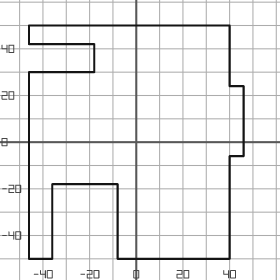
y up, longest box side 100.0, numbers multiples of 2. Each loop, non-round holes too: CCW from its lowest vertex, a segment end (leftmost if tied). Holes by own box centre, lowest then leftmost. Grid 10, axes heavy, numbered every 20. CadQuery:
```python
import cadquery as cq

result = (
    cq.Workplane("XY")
    .moveTo(-46.0, -50.0)
    .lineTo(-36.0, -50.0)
    .lineTo(-36.0, -18.0)
    .lineTo(-8.0, -18.0)
    .lineTo(-8.0, -50.0)
    .lineTo(40.0, -50.0)
    .lineTo(40.0, -6.0)
    .lineTo(46.0, -6.0)
    .lineTo(46.0, 24.0)
    .lineTo(40.0, 24.0)
    .lineTo(40.0, 50.0)
    .lineTo(-46.0, 50.0)
    .lineTo(-46.0, 42.0)
    .lineTo(-18.0, 42.0)
    .lineTo(-18.0, 30.0)
    .lineTo(-46.0, 30.0)
    .close()
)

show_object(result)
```